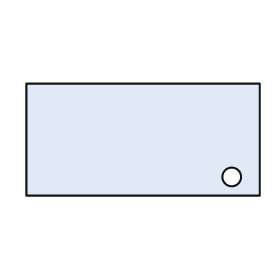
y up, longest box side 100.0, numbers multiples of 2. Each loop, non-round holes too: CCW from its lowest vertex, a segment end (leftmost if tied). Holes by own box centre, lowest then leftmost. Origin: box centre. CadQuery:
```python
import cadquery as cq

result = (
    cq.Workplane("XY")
    .moveTo(-50.0, -24.0)
    .lineTo(50.0, -24.0)
    .lineTo(50.0, 24.0)
    .lineTo(-50.0, 24.0)
    .close()
    .moveTo(38.0, -16.0)
    .circle(4.0)
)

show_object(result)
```